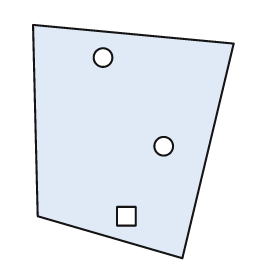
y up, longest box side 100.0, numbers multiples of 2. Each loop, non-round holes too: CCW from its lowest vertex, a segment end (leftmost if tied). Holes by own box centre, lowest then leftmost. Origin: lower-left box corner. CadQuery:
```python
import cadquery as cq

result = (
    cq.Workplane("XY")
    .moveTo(64.0, 0.0)
    .lineTo(86.0, 92.0)
    .lineTo(0.0, 100.0)
    .lineTo(2.0, 18.0)
    .close()
    .moveTo(36.0, 14.0)
    .lineTo(44.0, 14.0)
    .lineTo(44.0, 22.0)
    .lineTo(36.0, 22.0)
    .close()
    .moveTo(56.0, 48.0)
    .circle(4.0)
    .moveTo(30.0, 86.0)
    .circle(4.0)
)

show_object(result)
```